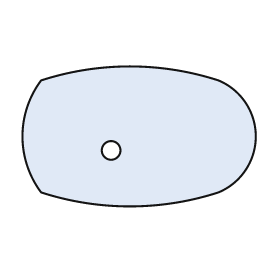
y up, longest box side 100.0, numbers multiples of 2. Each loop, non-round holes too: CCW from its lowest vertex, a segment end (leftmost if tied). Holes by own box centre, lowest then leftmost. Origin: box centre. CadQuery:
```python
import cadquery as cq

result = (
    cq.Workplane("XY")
    .moveTo(-42.0, -24.0)
    .threePointArc((-4.0, -30.0), (34.0, -24.0))
    .threePointArc((50.0, 0.0), (34.0, 24.0))
    .threePointArc((-4.0, 30.0), (-42.0, 24.0))
    .threePointArc((-50.0, 0.0), (-42.0, -24.0))
    .close()
    .moveTo(-12.0, -6.0)
    .circle(4.0)
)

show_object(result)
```